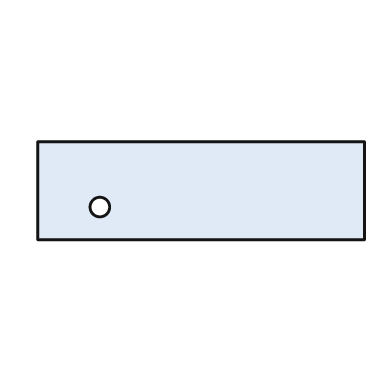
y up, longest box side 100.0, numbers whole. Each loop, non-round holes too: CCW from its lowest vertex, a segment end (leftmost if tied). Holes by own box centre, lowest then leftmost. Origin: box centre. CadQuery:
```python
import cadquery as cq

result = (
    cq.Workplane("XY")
    .moveTo(-50.0, -15.0)
    .lineTo(50.0, -15.0)
    .lineTo(50.0, 15.0)
    .lineTo(-50.0, 15.0)
    .close()
    .moveTo(-31.0, -5.0)
    .circle(3.0)
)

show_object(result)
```